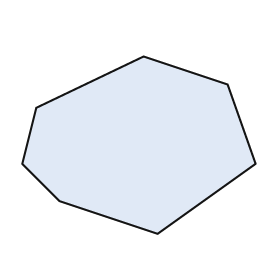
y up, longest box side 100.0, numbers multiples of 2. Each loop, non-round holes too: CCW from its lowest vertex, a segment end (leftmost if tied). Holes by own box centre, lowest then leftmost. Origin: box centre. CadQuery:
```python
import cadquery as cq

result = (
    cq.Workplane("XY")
    .moveTo(8.0, -38.0)
    .lineTo(50.0, -8.0)
    .lineTo(38.0, 26.0)
    .lineTo(2.0, 38.0)
    .lineTo(-44.0, 16.0)
    .lineTo(-50.0, -8.0)
    .lineTo(-34.0, -24.0)
    .close()
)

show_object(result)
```